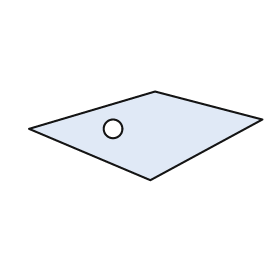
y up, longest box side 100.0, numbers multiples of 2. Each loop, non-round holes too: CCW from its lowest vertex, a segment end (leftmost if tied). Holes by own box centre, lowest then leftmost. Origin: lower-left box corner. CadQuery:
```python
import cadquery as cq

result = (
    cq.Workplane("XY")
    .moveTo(52.0, 0.0)
    .lineTo(100.0, 26.0)
    .lineTo(54.0, 38.0)
    .lineTo(0.0, 22.0)
    .close()
    .moveTo(36.0, 22.0)
    .circle(4.0)
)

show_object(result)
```